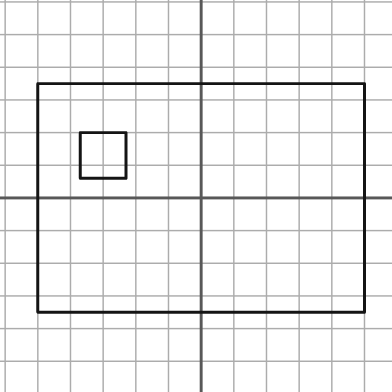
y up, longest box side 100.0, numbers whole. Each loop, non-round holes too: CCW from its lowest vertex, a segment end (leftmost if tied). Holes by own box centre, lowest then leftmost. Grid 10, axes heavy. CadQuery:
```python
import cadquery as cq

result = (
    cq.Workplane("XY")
    .moveTo(-50.0, -35.0)
    .lineTo(50.0, -35.0)
    .lineTo(50.0, 35.0)
    .lineTo(-50.0, 35.0)
    .close()
    .moveTo(-37.0, 6.0)
    .lineTo(-23.0, 6.0)
    .lineTo(-23.0, 20.0)
    .lineTo(-37.0, 20.0)
    .close()
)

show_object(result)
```